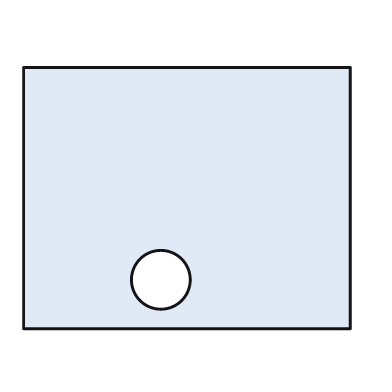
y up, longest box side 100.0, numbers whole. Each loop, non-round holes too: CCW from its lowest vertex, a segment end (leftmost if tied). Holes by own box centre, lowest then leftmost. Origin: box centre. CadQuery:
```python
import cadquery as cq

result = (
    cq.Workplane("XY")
    .moveTo(-50.0, -40.0)
    .lineTo(50.0, -40.0)
    .lineTo(50.0, 40.0)
    .lineTo(-50.0, 40.0)
    .close()
    .moveTo(-8.0, -25.0)
    .circle(9.0)
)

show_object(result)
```